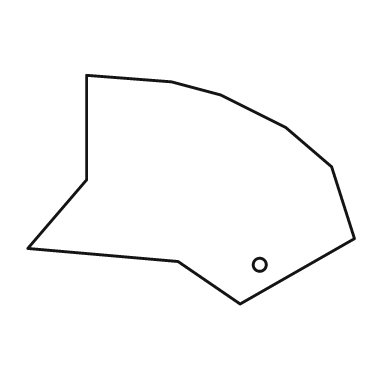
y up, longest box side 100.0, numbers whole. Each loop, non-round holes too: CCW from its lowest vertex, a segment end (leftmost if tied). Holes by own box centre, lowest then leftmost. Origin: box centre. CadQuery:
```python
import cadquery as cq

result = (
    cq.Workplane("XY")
    .moveTo(15.0, -35.0)
    .lineTo(50.0, -15.0)
    .lineTo(43.0, 7.0)
    .lineTo(29.0, 19.0)
    .lineTo(9.0, 29.0)
    .lineTo(-6.0, 33.0)
    .lineTo(-32.0, 35.0)
    .lineTo(-32.0, 3.0)
    .lineTo(-50.0, -18.0)
    .lineTo(-4.0, -22.0)
    .close()
    .moveTo(21.0, -23.0)
    .circle(2.0)
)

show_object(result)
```